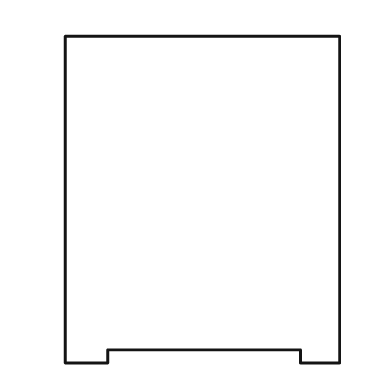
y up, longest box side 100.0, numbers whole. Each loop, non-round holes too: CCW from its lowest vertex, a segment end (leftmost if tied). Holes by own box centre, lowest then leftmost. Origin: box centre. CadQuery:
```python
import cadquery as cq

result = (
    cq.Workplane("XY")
    .moveTo(-42.0, -50.0)
    .lineTo(-29.0, -50.0)
    .lineTo(-29.0, -46.0)
    .lineTo(30.0, -46.0)
    .lineTo(30.0, -50.0)
    .lineTo(42.0, -50.0)
    .lineTo(42.0, 50.0)
    .lineTo(-42.0, 50.0)
    .close()
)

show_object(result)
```